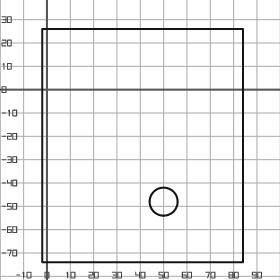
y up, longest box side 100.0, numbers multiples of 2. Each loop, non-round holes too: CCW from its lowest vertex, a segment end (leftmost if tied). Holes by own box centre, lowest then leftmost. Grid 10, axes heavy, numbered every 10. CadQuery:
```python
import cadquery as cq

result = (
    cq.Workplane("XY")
    .moveTo(-2.0, -74.0)
    .lineTo(84.0, -74.0)
    .lineTo(84.0, 26.0)
    .lineTo(-2.0, 26.0)
    .close()
    .moveTo(50.0, -48.0)
    .circle(6.0)
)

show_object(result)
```